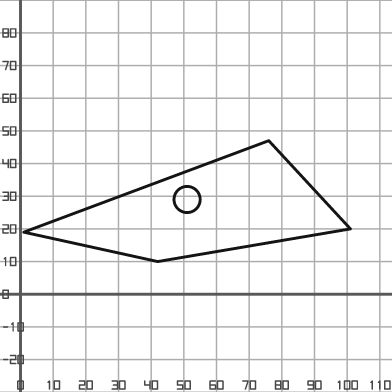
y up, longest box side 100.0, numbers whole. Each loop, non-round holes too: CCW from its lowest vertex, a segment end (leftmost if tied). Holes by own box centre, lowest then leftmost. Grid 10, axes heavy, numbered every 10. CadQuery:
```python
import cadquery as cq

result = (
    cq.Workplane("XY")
    .moveTo(42.0, 10.0)
    .lineTo(101.0, 20.0)
    .lineTo(76.0, 47.0)
    .lineTo(1.0, 19.0)
    .close()
    .moveTo(51.0, 29.0)
    .circle(4.0)
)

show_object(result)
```